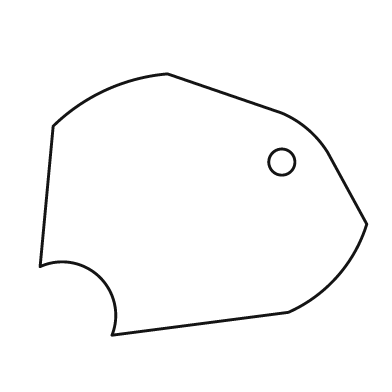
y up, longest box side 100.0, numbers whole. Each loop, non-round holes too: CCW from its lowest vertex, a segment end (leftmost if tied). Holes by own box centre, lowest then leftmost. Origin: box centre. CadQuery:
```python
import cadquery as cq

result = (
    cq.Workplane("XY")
    .moveTo(-28.0, -40.0)
    .lineTo(26.0, -33.0)
    .threePointArc((41.0, -22.0), (50.0, -6.0))
    .lineTo(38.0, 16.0)
    .threePointArc((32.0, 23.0), (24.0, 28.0))
    .lineTo(-11.0, 40.0)
    .threePointArc((-30.0, 35.0), (-46.0, 24.0))
    .lineTo(-50.0, -19.0)
    .threePointArc((-32.0, -22.0), (-28.0, -40.0))
    .close()
    .moveTo(24.0, 13.0)
    .circle(4.0)
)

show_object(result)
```